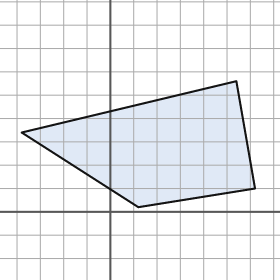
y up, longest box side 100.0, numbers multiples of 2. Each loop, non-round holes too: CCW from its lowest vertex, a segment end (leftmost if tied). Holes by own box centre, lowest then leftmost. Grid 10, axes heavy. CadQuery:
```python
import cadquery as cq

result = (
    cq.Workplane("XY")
    .moveTo(12.0, 2.0)
    .lineTo(62.0, 10.0)
    .lineTo(54.0, 56.0)
    .lineTo(-38.0, 34.0)
    .close()
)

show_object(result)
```